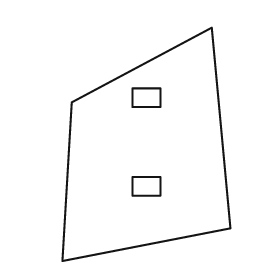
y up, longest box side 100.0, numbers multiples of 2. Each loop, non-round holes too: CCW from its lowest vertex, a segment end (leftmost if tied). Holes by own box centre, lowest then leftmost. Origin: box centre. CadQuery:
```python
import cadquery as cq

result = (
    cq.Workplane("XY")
    .moveTo(-36.0, -50.0)
    .lineTo(36.0, -36.0)
    .lineTo(28.0, 50.0)
    .lineTo(-32.0, 18.0)
    .close()
    .moveTo(-6.0, -22.0)
    .lineTo(6.0, -22.0)
    .lineTo(6.0, -14.0)
    .lineTo(-6.0, -14.0)
    .close()
    .moveTo(-6.0, 16.0)
    .lineTo(6.0, 16.0)
    .lineTo(6.0, 24.0)
    .lineTo(-6.0, 24.0)
    .close()
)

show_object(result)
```